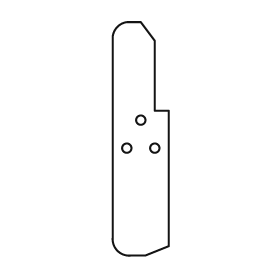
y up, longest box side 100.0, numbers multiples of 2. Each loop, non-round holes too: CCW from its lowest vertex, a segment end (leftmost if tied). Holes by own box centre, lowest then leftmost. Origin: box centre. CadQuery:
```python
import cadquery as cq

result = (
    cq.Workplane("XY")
    .moveTo(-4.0, -50.0)
    .lineTo(2.0, -50.0)
    .lineTo(12.0, -46.0)
    .lineTo(12.0, 12.0)
    .lineTo(6.0, 12.0)
    .lineTo(6.0, 42.0)
    .lineTo(0.0, 50.0)
    .lineTo(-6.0, 50.0)
    .threePointArc((-10.0, 48.0), (-12.0, 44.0))
    .lineTo(-12.0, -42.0)
    .threePointArc((-10.0, -48.0), (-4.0, -50.0))
    .close()
    .moveTo(-6.0, -4.0)
    .circle(2.0)
    .moveTo(6.0, -4.0)
    .circle(2.0)
    .moveTo(0.0, 8.0)
    .circle(2.0)
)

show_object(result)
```